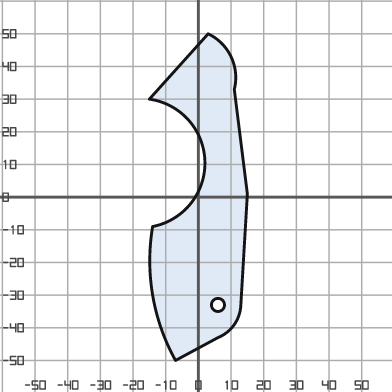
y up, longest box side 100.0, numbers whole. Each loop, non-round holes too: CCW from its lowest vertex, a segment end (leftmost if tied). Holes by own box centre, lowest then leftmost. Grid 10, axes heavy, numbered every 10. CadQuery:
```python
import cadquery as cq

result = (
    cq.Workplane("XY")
    .moveTo(-7.0, -50.0)
    .lineTo(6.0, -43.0)
    .threePointArc((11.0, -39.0), (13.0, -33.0))
    .lineTo(15.0, 1.0)
    .lineTo(11.0, 33.0)
    .threePointArc((10.0, 43.0), (3.0, 50.0))
    .lineTo(-15.0, 30.0)
    .threePointArc((2.0, 11.0), (-14.0, -9.0))
    .threePointArc((-14.0, -30.0), (-7.0, -50.0))
    .close()
    .moveTo(6.0, -33.0)
    .circle(2.0)
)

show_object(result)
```